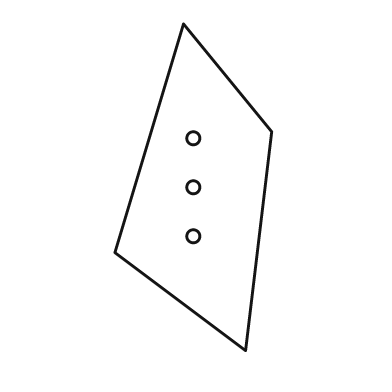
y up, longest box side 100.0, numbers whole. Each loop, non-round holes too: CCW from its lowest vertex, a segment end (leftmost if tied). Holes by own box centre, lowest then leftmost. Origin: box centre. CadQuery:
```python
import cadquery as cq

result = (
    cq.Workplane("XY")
    .moveTo(16.0, -50.0)
    .lineTo(24.0, 17.0)
    .lineTo(-3.0, 50.0)
    .lineTo(-24.0, -20.0)
    .close()
    .moveTo(0.0, -15.0)
    .circle(2.0)
    .moveTo(0.0, 0.0)
    .circle(2.0)
    .moveTo(0.0, 15.0)
    .circle(2.0)
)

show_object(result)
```